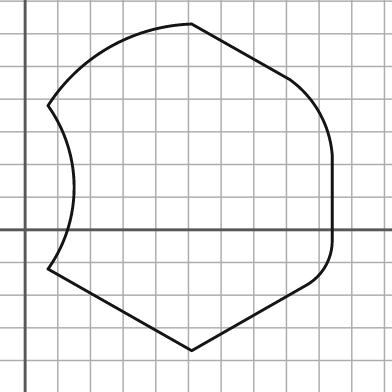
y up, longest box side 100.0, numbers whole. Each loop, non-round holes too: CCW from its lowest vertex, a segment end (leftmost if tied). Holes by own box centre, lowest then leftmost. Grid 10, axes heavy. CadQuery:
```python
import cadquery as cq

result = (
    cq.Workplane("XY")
    .moveTo(51.0, -37.0)
    .lineTo(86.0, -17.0)
    .threePointArc((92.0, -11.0), (94.0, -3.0))
    .lineTo(94.0, 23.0)
    .threePointArc((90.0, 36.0), (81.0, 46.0))
    .lineTo(51.0, 63.0)
    .threePointArc((26.0, 56.0), (7.0, 38.0))
    .threePointArc((15.0, 13.0), (7.0, -12.0))
    .close()
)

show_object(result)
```